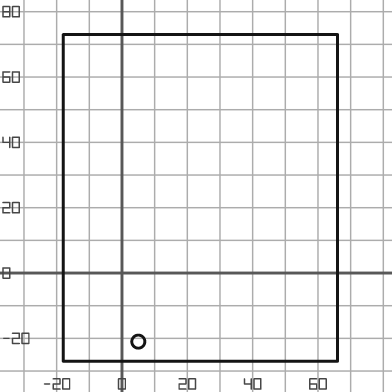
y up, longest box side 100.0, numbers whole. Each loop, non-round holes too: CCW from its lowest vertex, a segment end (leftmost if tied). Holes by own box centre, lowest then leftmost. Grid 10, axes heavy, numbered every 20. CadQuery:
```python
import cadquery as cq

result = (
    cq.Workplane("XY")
    .moveTo(-18.0, -27.0)
    .lineTo(66.0, -27.0)
    .lineTo(66.0, 73.0)
    .lineTo(-18.0, 73.0)
    .close()
    .moveTo(5.0, -21.0)
    .circle(2.0)
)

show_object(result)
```